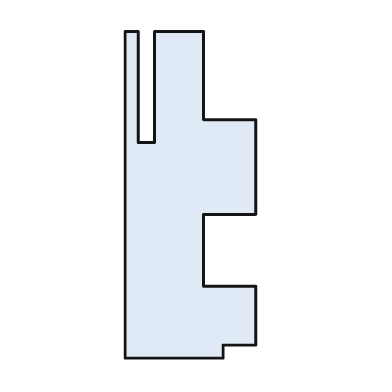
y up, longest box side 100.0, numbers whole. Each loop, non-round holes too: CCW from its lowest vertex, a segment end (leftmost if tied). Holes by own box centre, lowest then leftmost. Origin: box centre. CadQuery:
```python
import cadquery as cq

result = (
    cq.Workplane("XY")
    .moveTo(-20.0, -50.0)
    .lineTo(10.0, -50.0)
    .lineTo(10.0, -46.0)
    .lineTo(20.0, -46.0)
    .lineTo(20.0, -28.0)
    .lineTo(4.0, -28.0)
    .lineTo(4.0, -6.0)
    .lineTo(20.0, -6.0)
    .lineTo(20.0, 23.0)
    .lineTo(4.0, 23.0)
    .lineTo(4.0, 50.0)
    .lineTo(-11.0, 50.0)
    .lineTo(-11.0, 16.0)
    .lineTo(-16.0, 16.0)
    .lineTo(-16.0, 50.0)
    .lineTo(-20.0, 50.0)
    .close()
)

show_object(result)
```